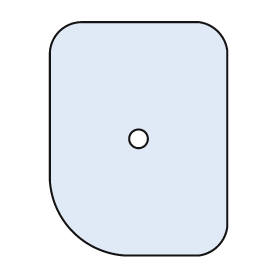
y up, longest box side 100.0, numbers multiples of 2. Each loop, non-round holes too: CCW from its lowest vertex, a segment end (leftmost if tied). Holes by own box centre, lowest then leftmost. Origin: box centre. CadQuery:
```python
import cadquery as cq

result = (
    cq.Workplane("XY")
    .moveTo(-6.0, -50.0)
    .lineTo(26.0, -50.0)
    .threePointArc((34.0, -46.0), (38.0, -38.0))
    .lineTo(38.0, 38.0)
    .threePointArc((34.0, 46.0), (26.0, 50.0))
    .lineTo(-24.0, 50.0)
    .threePointArc((-34.0, 46.0), (-38.0, 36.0))
    .lineTo(-38.0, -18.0)
    .threePointArc((-28.0, -40.0), (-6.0, -50.0))
    .close()
    .moveTo(0.0, 0.0)
    .circle(4.0)
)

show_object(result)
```